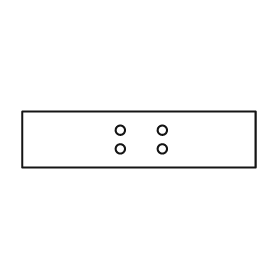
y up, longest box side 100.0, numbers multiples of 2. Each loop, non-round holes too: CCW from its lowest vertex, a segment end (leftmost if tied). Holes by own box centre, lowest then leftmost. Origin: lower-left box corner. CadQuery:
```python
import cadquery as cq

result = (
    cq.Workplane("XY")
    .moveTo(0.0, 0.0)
    .lineTo(100.0, 0.0)
    .lineTo(100.0, 24.0)
    .lineTo(0.0, 24.0)
    .close()
    .moveTo(42.0, 8.0)
    .circle(2.0)
    .moveTo(60.0, 8.0)
    .circle(2.0)
    .moveTo(42.0, 16.0)
    .circle(2.0)
    .moveTo(60.0, 16.0)
    .circle(2.0)
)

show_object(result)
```